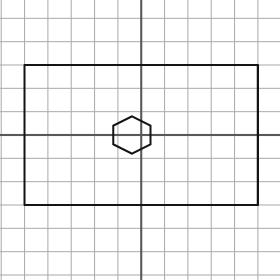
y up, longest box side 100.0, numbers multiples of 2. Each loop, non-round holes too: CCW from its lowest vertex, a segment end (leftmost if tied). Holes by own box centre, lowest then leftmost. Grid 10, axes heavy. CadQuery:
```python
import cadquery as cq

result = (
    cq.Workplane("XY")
    .moveTo(-50.0, -30.0)
    .lineTo(50.0, -30.0)
    .lineTo(50.0, 30.0)
    .lineTo(-50.0, 30.0)
    .close()
    .moveTo(-4.0, -8.0)
    .lineTo(4.0, -4.0)
    .lineTo(4.0, 4.0)
    .lineTo(-4.0, 8.0)
    .lineTo(-12.0, 4.0)
    .lineTo(-12.0, -4.0)
    .close()
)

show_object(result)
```